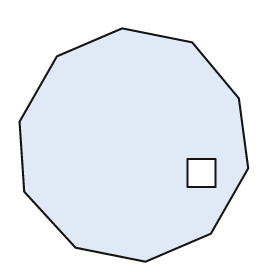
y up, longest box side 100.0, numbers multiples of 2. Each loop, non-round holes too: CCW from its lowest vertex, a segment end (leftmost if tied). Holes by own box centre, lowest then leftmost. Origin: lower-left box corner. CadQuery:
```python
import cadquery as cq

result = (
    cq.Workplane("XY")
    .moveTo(54.0, 0.0)
    .lineTo(82.0, 12.0)
    .lineTo(98.0, 40.0)
    .lineTo(94.0, 70.0)
    .lineTo(74.0, 94.0)
    .lineTo(44.0, 100.0)
    .lineTo(16.0, 88.0)
    .lineTo(0.0, 60.0)
    .lineTo(2.0, 30.0)
    .lineTo(24.0, 6.0)
    .close()
    .moveTo(72.0, 32.0)
    .lineTo(84.0, 32.0)
    .lineTo(84.0, 44.0)
    .lineTo(72.0, 44.0)
    .close()
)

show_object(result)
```